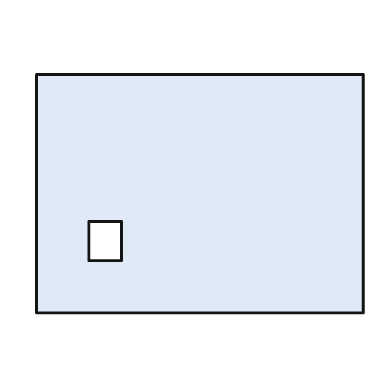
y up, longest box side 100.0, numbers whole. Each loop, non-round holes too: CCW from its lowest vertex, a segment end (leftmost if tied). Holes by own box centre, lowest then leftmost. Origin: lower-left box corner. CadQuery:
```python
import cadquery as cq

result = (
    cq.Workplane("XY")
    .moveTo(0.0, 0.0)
    .lineTo(100.0, 0.0)
    .lineTo(100.0, 73.0)
    .lineTo(0.0, 73.0)
    .close()
    .moveTo(16.0, 16.0)
    .lineTo(26.0, 16.0)
    .lineTo(26.0, 28.0)
    .lineTo(16.0, 28.0)
    .close()
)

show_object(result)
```